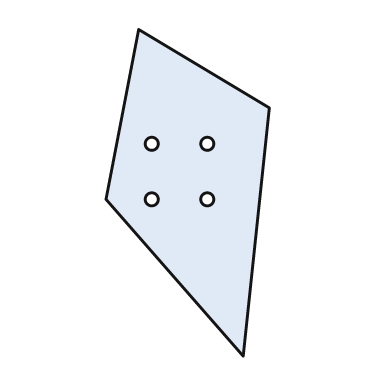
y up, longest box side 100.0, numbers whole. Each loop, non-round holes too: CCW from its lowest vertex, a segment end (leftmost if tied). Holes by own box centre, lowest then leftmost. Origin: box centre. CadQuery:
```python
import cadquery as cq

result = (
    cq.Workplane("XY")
    .moveTo(17.0, -50.0)
    .lineTo(25.0, 26.0)
    .lineTo(-15.0, 50.0)
    .lineTo(-25.0, -2.0)
    .close()
    .moveTo(-11.0, -2.0)
    .circle(2.0)
    .moveTo(6.0, -2.0)
    .circle(2.0)
    .moveTo(-11.0, 15.0)
    .circle(2.0)
    .moveTo(6.0, 15.0)
    .circle(2.0)
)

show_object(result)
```